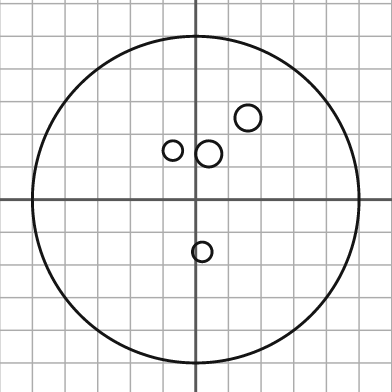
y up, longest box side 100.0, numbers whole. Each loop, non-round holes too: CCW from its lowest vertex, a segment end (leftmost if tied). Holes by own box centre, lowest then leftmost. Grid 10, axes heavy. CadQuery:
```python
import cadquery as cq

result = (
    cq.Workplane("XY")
    .moveTo(0.0, 0.0)
    .circle(50.0)
    .moveTo(2.0, -16.0)
    .circle(3.0)
    .moveTo(4.0, 14.0)
    .circle(4.0)
    .moveTo(-7.0, 15.0)
    .circle(3.0)
    .moveTo(16.0, 25.0)
    .circle(4.0)
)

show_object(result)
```